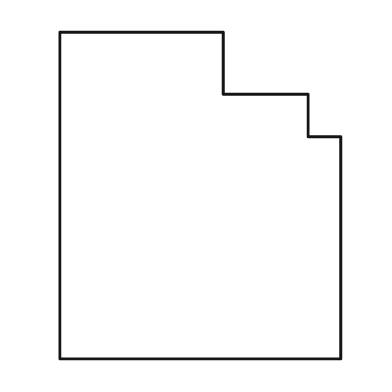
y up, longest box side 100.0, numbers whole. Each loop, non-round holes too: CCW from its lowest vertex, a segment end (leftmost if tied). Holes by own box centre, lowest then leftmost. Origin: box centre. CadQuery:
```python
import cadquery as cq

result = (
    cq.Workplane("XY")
    .moveTo(-43.0, -50.0)
    .lineTo(43.0, -50.0)
    .lineTo(43.0, 18.0)
    .lineTo(33.0, 18.0)
    .lineTo(33.0, 31.0)
    .lineTo(7.0, 31.0)
    .lineTo(7.0, 50.0)
    .lineTo(-43.0, 50.0)
    .close()
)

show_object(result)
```